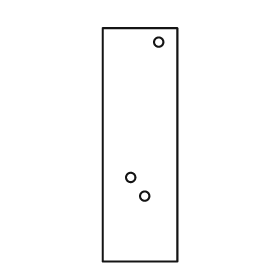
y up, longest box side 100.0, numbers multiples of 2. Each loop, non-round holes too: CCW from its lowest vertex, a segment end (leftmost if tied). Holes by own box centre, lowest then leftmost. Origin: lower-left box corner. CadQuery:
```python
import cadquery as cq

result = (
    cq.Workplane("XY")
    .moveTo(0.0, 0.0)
    .lineTo(32.0, 0.0)
    .lineTo(32.0, 100.0)
    .lineTo(0.0, 100.0)
    .close()
    .moveTo(18.0, 28.0)
    .circle(2.0)
    .moveTo(12.0, 36.0)
    .circle(2.0)
    .moveTo(24.0, 94.0)
    .circle(2.0)
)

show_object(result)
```